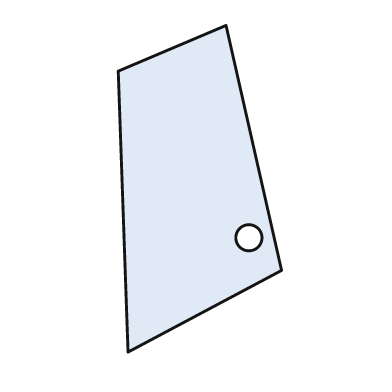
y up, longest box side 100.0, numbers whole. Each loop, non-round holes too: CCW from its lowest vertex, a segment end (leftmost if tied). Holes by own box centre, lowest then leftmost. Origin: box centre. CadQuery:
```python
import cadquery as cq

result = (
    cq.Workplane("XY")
    .moveTo(-22.0, -50.0)
    .lineTo(25.0, -25.0)
    .lineTo(8.0, 50.0)
    .lineTo(-25.0, 36.0)
    .close()
    .moveTo(15.0, -15.0)
    .circle(4.0)
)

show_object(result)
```